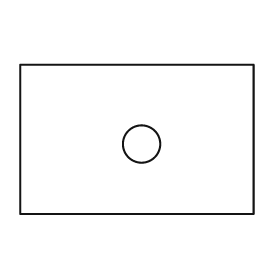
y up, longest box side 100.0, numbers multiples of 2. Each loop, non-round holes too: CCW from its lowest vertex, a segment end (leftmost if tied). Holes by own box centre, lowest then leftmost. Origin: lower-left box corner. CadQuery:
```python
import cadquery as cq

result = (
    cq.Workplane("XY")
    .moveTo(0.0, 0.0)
    .lineTo(100.0, 0.0)
    .lineTo(100.0, 64.0)
    .lineTo(0.0, 64.0)
    .close()
    .moveTo(52.0, 30.0)
    .circle(8.0)
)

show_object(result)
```